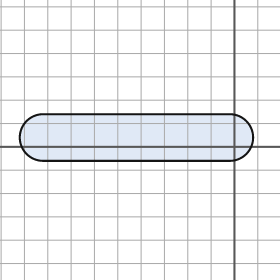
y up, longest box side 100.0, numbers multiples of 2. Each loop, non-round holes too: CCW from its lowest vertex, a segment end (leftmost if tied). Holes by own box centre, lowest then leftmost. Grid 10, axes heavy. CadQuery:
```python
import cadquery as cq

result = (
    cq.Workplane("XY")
    .moveTo(-82.0, -6.0)
    .lineTo(-2.0, -6.0)
    .threePointArc((8.0, 4.0), (-2.0, 14.0))
    .lineTo(-82.0, 14.0)
    .threePointArc((-92.0, 4.0), (-82.0, -6.0))
    .close()
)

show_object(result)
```